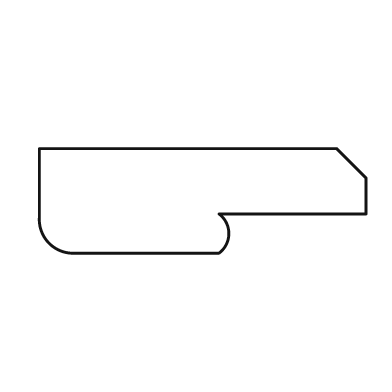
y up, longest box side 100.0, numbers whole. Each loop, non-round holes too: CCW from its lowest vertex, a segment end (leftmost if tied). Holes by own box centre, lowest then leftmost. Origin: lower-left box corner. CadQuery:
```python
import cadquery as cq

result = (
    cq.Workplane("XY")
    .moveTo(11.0, 0.0)
    .lineTo(55.0, 0.0)
    .threePointArc((58.0, 6.0), (55.0, 12.0))
    .lineTo(100.0, 12.0)
    .lineTo(100.0, 23.0)
    .lineTo(91.0, 32.0)
    .lineTo(0.0, 32.0)
    .lineTo(0.0, 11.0)
    .threePointArc((3.0, 3.0), (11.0, 0.0))
    .close()
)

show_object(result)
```